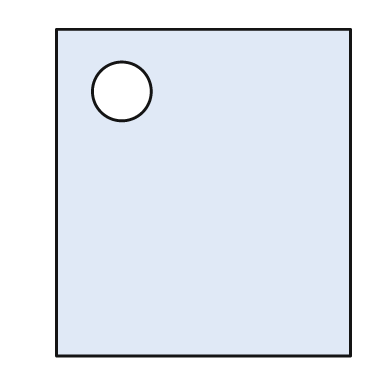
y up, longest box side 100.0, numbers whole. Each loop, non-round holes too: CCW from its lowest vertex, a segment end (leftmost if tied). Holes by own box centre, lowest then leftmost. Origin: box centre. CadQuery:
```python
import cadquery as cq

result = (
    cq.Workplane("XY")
    .moveTo(-45.0, -50.0)
    .lineTo(45.0, -50.0)
    .lineTo(45.0, 50.0)
    .lineTo(-45.0, 50.0)
    .close()
    .moveTo(-25.0, 31.0)
    .circle(9.0)
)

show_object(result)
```